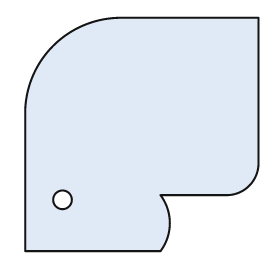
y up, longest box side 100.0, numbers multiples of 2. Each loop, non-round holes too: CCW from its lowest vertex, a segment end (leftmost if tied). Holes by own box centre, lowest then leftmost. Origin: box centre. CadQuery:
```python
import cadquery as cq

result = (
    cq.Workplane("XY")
    .moveTo(-50.0, -50.0)
    .lineTo(8.0, -50.0)
    .threePointArc((12.0, -38.0), (8.0, -26.0))
    .lineTo(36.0, -26.0)
    .threePointArc((46.0, -22.0), (50.0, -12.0))
    .lineTo(50.0, 50.0)
    .lineTo(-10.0, 50.0)
    .threePointArc((-38.0, 38.0), (-50.0, 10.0))
    .close()
    .moveTo(-34.0, -28.0)
    .circle(4.0)
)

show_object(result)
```